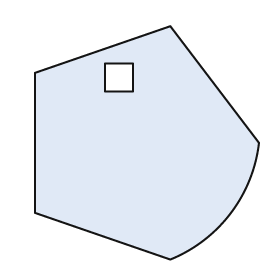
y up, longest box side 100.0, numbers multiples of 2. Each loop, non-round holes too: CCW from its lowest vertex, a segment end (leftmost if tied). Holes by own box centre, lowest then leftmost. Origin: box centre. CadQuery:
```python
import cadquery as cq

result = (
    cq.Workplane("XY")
    .moveTo(10.0, -50.0)
    .threePointArc((36.0, -30.0), (48.0, 0.0))
    .lineTo(10.0, 50.0)
    .lineTo(-48.0, 30.0)
    .lineTo(-48.0, -30.0)
    .close()
    .moveTo(-18.0, 22.0)
    .lineTo(-6.0, 22.0)
    .lineTo(-6.0, 34.0)
    .lineTo(-18.0, 34.0)
    .close()
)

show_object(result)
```